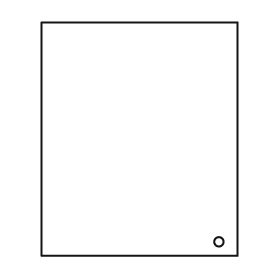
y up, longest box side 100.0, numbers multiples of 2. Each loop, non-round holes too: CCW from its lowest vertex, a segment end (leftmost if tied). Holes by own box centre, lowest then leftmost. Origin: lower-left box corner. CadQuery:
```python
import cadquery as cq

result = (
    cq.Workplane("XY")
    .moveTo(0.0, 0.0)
    .lineTo(84.0, 0.0)
    .lineTo(84.0, 100.0)
    .lineTo(0.0, 100.0)
    .close()
    .moveTo(76.0, 6.0)
    .circle(2.0)
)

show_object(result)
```